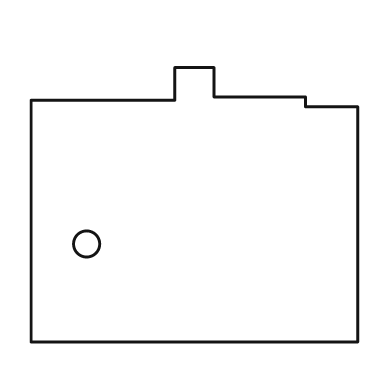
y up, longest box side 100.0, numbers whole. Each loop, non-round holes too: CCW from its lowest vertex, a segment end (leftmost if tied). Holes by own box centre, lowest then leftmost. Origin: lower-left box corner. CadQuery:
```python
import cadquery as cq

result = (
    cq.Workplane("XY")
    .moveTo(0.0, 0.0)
    .lineTo(100.0, 0.0)
    .lineTo(100.0, 72.0)
    .lineTo(84.0, 72.0)
    .lineTo(84.0, 75.0)
    .lineTo(56.0, 75.0)
    .lineTo(56.0, 84.0)
    .lineTo(44.0, 84.0)
    .lineTo(44.0, 74.0)
    .lineTo(0.0, 74.0)
    .close()
    .moveTo(17.0, 30.0)
    .circle(4.0)
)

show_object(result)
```